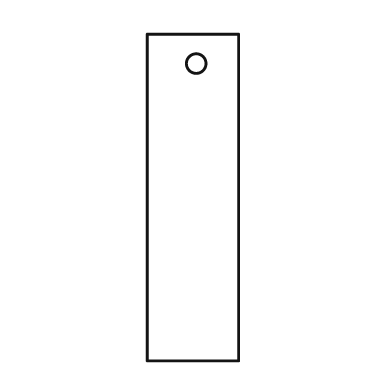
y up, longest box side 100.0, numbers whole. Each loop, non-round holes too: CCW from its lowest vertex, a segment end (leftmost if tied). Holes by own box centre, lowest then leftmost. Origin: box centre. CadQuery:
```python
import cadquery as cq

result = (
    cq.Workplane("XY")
    .moveTo(-14.0, -50.0)
    .lineTo(14.0, -50.0)
    .lineTo(14.0, 50.0)
    .lineTo(-14.0, 50.0)
    .close()
    .moveTo(1.0, 41.0)
    .circle(3.0)
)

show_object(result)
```